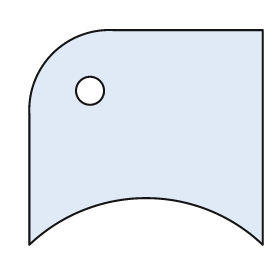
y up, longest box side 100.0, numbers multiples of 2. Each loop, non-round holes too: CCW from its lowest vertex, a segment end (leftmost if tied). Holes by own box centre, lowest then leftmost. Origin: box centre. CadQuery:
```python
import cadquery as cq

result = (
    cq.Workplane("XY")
    .moveTo(-50.0, -46.0)
    .threePointArc((0.0, -26.0), (50.0, -46.0))
    .lineTo(50.0, 46.0)
    .lineTo(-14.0, 46.0)
    .threePointArc((-40.0, 36.0), (-50.0, 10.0))
    .close()
    .moveTo(-24.0, 20.0)
    .circle(6.0)
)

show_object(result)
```